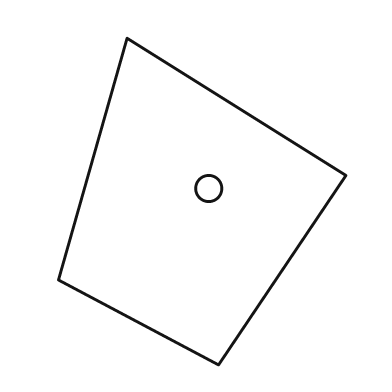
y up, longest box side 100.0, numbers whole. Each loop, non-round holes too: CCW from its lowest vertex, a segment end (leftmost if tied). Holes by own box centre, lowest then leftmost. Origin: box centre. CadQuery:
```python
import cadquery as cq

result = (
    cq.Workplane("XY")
    .moveTo(5.0, -50.0)
    .lineTo(44.0, 8.0)
    .lineTo(-23.0, 50.0)
    .lineTo(-44.0, -24.0)
    .close()
    .moveTo(2.0, 4.0)
    .circle(4.0)
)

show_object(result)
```